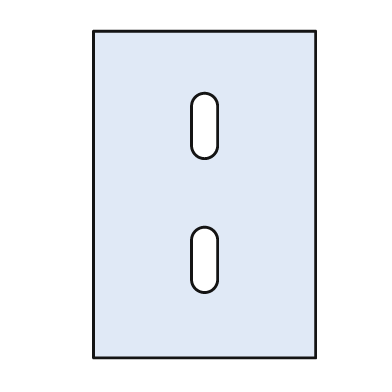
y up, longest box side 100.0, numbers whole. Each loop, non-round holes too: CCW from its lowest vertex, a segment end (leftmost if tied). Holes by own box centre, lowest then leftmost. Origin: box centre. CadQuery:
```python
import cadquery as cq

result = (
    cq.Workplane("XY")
    .moveTo(-34.0, -50.0)
    .lineTo(34.0, -50.0)
    .lineTo(34.0, 50.0)
    .lineTo(-34.0, 50.0)
    .close()
    .moveTo(-4.0, -26.0)
    .threePointArc((0.0, -30.0), (4.0, -26.0))
    .lineTo(4.0, -14.0)
    .threePointArc((0.0, -10.0), (-4.0, -14.0))
    .close()
    .moveTo(-4.0, 15.0)
    .threePointArc((0.0, 11.0), (4.0, 15.0))
    .lineTo(4.0, 27.0)
    .threePointArc((0.0, 31.0), (-4.0, 27.0))
    .close()
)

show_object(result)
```